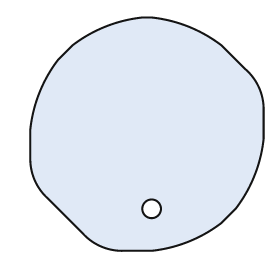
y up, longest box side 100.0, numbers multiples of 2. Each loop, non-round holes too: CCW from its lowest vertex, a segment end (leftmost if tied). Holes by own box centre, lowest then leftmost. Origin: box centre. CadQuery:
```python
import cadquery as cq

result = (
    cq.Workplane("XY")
    .moveTo(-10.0, -50.0)
    .lineTo(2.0, -50.0)
    .threePointArc((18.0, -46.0), (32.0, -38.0))
    .lineTo(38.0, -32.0)
    .threePointArc((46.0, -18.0), (50.0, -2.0))
    .lineTo(50.0, 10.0)
    .threePointArc((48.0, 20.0), (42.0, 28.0))
    .lineTo(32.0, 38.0)
    .threePointArc((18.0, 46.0), (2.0, 50.0))
    .lineTo(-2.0, 50.0)
    .threePointArc((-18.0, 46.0), (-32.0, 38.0))
    .lineTo(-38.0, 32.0)
    .threePointArc((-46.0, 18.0), (-50.0, 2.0))
    .lineTo(-50.0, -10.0)
    .threePointArc((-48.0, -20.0), (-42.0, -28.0))
    .lineTo(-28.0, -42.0)
    .threePointArc((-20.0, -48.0), (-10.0, -50.0))
    .close()
    .moveTo(2.0, -32.0)
    .circle(4.0)
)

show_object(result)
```